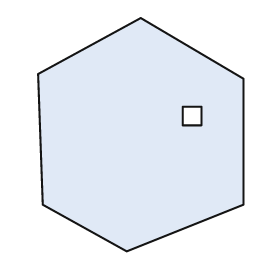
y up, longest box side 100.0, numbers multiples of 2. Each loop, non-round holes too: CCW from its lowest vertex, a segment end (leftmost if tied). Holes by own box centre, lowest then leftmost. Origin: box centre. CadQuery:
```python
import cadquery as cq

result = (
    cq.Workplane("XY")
    .moveTo(-6.0, -50.0)
    .lineTo(44.0, -30.0)
    .lineTo(44.0, 24.0)
    .lineTo(0.0, 50.0)
    .lineTo(-44.0, 26.0)
    .lineTo(-42.0, -30.0)
    .close()
    .moveTo(18.0, 4.0)
    .lineTo(26.0, 4.0)
    .lineTo(26.0, 12.0)
    .lineTo(18.0, 12.0)
    .close()
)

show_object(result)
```